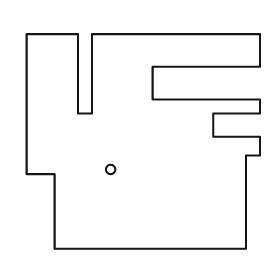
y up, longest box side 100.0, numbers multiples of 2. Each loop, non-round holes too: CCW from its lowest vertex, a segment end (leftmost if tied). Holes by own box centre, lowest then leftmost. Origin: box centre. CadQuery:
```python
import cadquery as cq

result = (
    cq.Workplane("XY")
    .moveTo(-38.0, -46.0)
    .lineTo(44.0, -46.0)
    .lineTo(44.0, -6.0)
    .lineTo(50.0, -6.0)
    .lineTo(50.0, 2.0)
    .lineTo(30.0, 2.0)
    .lineTo(30.0, 12.0)
    .lineTo(50.0, 12.0)
    .lineTo(50.0, 18.0)
    .lineTo(4.0, 18.0)
    .lineTo(4.0, 32.0)
    .lineTo(50.0, 32.0)
    .lineTo(50.0, 46.0)
    .lineTo(-22.0, 46.0)
    .lineTo(-22.0, 12.0)
    .lineTo(-28.0, 12.0)
    .lineTo(-28.0, 46.0)
    .lineTo(-50.0, 46.0)
    .lineTo(-50.0, -14.0)
    .lineTo(-38.0, -14.0)
    .close()
    .moveTo(-14.0, -12.0)
    .circle(2.0)
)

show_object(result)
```